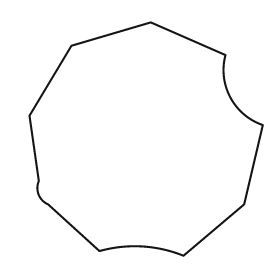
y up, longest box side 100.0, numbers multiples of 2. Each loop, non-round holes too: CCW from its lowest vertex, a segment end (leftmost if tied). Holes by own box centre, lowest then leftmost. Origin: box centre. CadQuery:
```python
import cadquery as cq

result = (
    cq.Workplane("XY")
    .moveTo(16.0, -50.0)
    .lineTo(42.0, -28.0)
    .lineTo(50.0, 6.0)
    .threePointArc((36.0, 18.0), (34.0, 36.0))
    .lineTo(2.0, 50.0)
    .lineTo(-32.0, 40.0)
    .lineTo(-50.0, 10.0)
    .lineTo(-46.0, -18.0)
    .threePointArc((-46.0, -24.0), (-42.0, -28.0))
    .lineTo(-20.0, -48.0)
    .threePointArc((-2.0, -46.0), (16.0, -50.0))
    .close()
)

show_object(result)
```